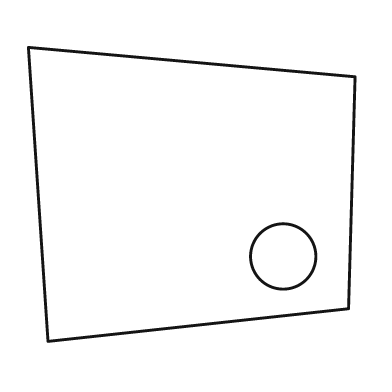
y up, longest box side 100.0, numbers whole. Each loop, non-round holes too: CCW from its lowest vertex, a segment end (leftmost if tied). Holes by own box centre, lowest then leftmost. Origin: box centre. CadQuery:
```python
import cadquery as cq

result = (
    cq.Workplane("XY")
    .moveTo(-44.0, -45.0)
    .lineTo(48.0, -35.0)
    .lineTo(50.0, 36.0)
    .lineTo(-50.0, 45.0)
    .close()
    .moveTo(28.0, -19.0)
    .circle(10.0)
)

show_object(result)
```